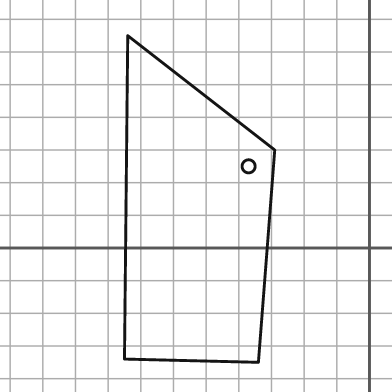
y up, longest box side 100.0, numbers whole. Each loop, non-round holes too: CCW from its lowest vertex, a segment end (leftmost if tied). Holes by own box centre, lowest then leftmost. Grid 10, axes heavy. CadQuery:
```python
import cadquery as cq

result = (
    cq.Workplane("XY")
    .moveTo(-34.0, -35.0)
    .lineTo(-29.0, 30.0)
    .lineTo(-74.0, 65.0)
    .lineTo(-75.0, -34.0)
    .close()
    .moveTo(-37.0, 25.0)
    .circle(2.0)
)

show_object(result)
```